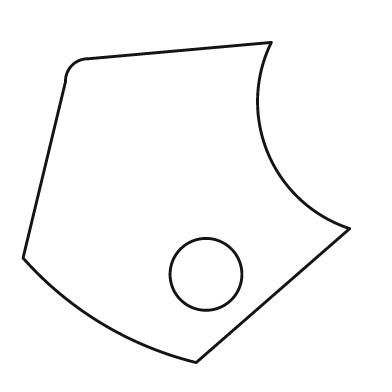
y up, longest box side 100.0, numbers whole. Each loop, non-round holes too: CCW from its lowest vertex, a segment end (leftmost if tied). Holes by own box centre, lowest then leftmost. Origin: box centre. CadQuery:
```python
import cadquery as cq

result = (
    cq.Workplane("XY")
    .moveTo(3.0, -49.0)
    .lineTo(50.0, -8.0)
    .threePointArc((25.0, 15.0), (26.0, 49.0))
    .lineTo(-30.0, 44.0)
    .threePointArc((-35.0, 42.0), (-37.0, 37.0))
    .lineTo(-50.0, -17.0)
    .threePointArc((-26.0, -37.0), (3.0, -49.0))
    .close()
    .moveTo(6.0, -22.0)
    .circle(11.0)
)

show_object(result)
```